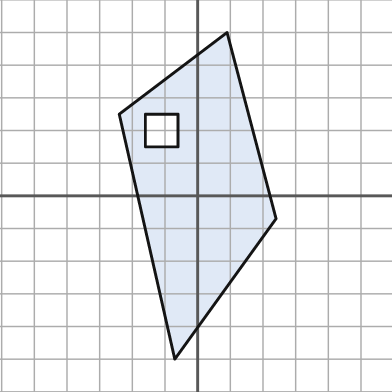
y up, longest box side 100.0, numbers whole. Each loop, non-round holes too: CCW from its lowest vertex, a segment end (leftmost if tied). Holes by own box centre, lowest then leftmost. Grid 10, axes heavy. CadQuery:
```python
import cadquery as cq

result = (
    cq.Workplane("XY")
    .moveTo(-7.0, -50.0)
    .lineTo(24.0, -7.0)
    .lineTo(9.0, 50.0)
    .lineTo(-24.0, 25.0)
    .close()
    .moveTo(-16.0, 15.0)
    .lineTo(-6.0, 15.0)
    .lineTo(-6.0, 25.0)
    .lineTo(-16.0, 25.0)
    .close()
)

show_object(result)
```